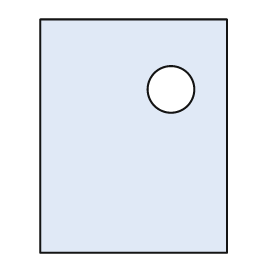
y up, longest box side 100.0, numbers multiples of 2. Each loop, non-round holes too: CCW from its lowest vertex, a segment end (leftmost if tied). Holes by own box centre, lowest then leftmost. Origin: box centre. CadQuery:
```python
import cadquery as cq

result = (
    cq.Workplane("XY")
    .moveTo(-40.0, -50.0)
    .lineTo(40.0, -50.0)
    .lineTo(40.0, 50.0)
    .lineTo(-40.0, 50.0)
    .close()
    .moveTo(16.0, 20.0)
    .circle(10.0)
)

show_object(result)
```